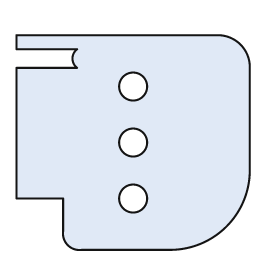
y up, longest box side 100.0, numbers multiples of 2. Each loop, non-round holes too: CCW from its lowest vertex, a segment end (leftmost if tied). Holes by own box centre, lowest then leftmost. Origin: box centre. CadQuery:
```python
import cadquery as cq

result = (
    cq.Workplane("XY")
    .moveTo(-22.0, -46.0)
    .lineTo(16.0, -46.0)
    .threePointArc((40.0, -36.0), (50.0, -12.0))
    .lineTo(50.0, 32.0)
    .threePointArc((46.0, 42.0), (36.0, 46.0))
    .lineTo(-50.0, 46.0)
    .lineTo(-50.0, 40.0)
    .lineTo(-24.0, 40.0)
    .threePointArc((-26.0, 36.0), (-24.0, 32.0))
    .lineTo(-50.0, 32.0)
    .lineTo(-50.0, -24.0)
    .lineTo(-30.0, -24.0)
    .lineTo(-30.0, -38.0)
    .threePointArc((-28.0, -44.0), (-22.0, -46.0))
    .close()
    .moveTo(0.0, -24.0)
    .circle(6.0)
    .moveTo(0.0, 0.0)
    .circle(6.0)
    .moveTo(0.0, 24.0)
    .circle(6.0)
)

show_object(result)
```